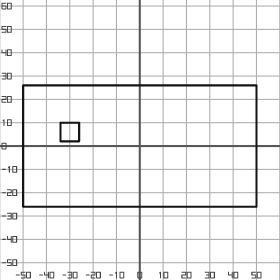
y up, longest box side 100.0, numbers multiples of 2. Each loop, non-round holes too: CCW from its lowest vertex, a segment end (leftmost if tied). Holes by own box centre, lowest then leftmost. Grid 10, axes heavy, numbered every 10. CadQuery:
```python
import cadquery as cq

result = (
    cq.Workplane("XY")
    .moveTo(-50.0, -26.0)
    .lineTo(50.0, -26.0)
    .lineTo(50.0, 26.0)
    .lineTo(-50.0, 26.0)
    .close()
    .moveTo(-34.0, 2.0)
    .lineTo(-26.0, 2.0)
    .lineTo(-26.0, 10.0)
    .lineTo(-34.0, 10.0)
    .close()
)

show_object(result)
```